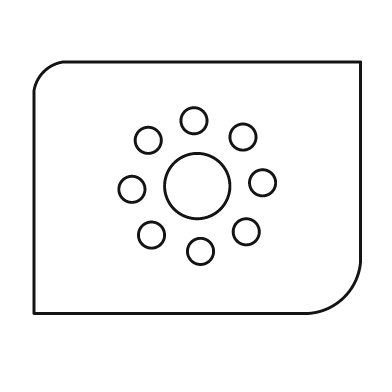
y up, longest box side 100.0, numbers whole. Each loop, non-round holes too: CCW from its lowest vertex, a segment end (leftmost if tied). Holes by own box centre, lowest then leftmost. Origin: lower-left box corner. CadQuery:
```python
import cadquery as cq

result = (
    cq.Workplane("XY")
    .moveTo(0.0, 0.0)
    .lineTo(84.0, 0.0)
    .threePointArc((95.0, 5.0), (100.0, 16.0))
    .lineTo(100.0, 77.0)
    .lineTo(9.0, 77.0)
    .threePointArc((3.0, 74.0), (0.0, 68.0))
    .close()
    .moveTo(51.0, 19.0)
    .circle(4.0)
    .moveTo(36.0, 24.0)
    .circle(4.0)
    .moveTo(65.0, 25.0)
    .circle(4.0)
    .moveTo(30.0, 38.0)
    .circle(4.0)
    .moveTo(50.0, 39.0)
    .circle(10.0)
    .moveTo(70.0, 40.0)
    .circle(4.0)
    .moveTo(35.0, 53.0)
    .circle(4.0)
    .moveTo(64.0, 54.0)
    .circle(4.0)
    .moveTo(49.0, 59.0)
    .circle(4.0)
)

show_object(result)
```